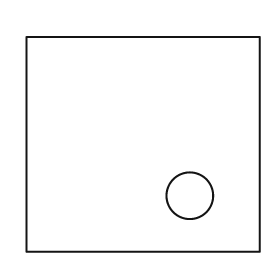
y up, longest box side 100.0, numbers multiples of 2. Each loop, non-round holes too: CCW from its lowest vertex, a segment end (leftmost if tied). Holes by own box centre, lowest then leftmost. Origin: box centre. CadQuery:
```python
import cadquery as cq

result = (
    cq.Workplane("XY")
    .moveTo(-50.0, -46.0)
    .lineTo(50.0, -46.0)
    .lineTo(50.0, 46.0)
    .lineTo(-50.0, 46.0)
    .close()
    .moveTo(20.0, -22.0)
    .circle(10.0)
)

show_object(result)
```